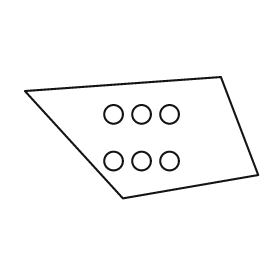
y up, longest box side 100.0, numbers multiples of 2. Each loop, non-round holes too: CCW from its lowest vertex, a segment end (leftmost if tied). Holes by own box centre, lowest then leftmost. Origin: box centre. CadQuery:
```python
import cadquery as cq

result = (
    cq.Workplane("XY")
    .moveTo(-8.0, -26.0)
    .lineTo(50.0, -16.0)
    .lineTo(34.0, 26.0)
    .lineTo(-50.0, 20.0)
    .close()
    .moveTo(-12.0, -10.0)
    .circle(4.0)
    .moveTo(0.0, -10.0)
    .circle(4.0)
    .moveTo(12.0, -10.0)
    .circle(4.0)
    .moveTo(-12.0, 10.0)
    .circle(4.0)
    .moveTo(0.0, 10.0)
    .circle(4.0)
    .moveTo(12.0, 10.0)
    .circle(4.0)
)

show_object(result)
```